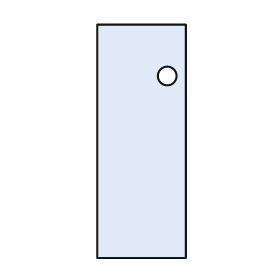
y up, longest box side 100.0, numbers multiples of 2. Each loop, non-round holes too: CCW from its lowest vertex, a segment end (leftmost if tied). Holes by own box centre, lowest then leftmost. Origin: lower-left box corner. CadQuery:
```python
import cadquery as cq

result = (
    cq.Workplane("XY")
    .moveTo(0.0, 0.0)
    .lineTo(38.0, 0.0)
    .lineTo(38.0, 100.0)
    .lineTo(0.0, 100.0)
    .close()
    .moveTo(30.0, 78.0)
    .circle(4.0)
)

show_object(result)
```